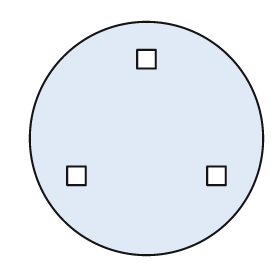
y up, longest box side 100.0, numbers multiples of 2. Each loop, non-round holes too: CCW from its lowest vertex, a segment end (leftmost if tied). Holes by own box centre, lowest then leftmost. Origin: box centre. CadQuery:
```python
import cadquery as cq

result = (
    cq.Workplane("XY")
    .moveTo(0.0, 0.0)
    .circle(50.0)
    .moveTo(-34.0, -20.0)
    .lineTo(-26.0, -20.0)
    .lineTo(-26.0, -12.0)
    .lineTo(-34.0, -12.0)
    .close()
    .moveTo(26.0, -20.0)
    .lineTo(34.0, -20.0)
    .lineTo(34.0, -12.0)
    .lineTo(26.0, -12.0)
    .close()
    .moveTo(-4.0, 30.0)
    .lineTo(4.0, 30.0)
    .lineTo(4.0, 38.0)
    .lineTo(-4.0, 38.0)
    .close()
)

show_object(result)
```